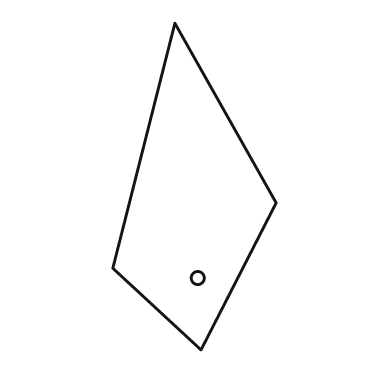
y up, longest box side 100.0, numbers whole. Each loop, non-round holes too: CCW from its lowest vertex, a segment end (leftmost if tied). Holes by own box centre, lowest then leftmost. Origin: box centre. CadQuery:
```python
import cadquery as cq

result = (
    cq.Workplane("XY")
    .moveTo(2.0, -50.0)
    .lineTo(25.0, -5.0)
    .lineTo(-6.0, 50.0)
    .lineTo(-25.0, -25.0)
    .close()
    .moveTo(1.0, -28.0)
    .circle(2.0)
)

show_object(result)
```